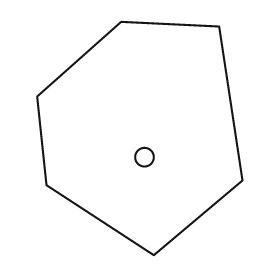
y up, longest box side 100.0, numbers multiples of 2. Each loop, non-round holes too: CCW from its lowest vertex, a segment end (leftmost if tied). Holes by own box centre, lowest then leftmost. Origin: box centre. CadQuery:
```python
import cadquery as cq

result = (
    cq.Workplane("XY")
    .moveTo(6.0, -50.0)
    .lineTo(44.0, -18.0)
    .lineTo(34.0, 48.0)
    .lineTo(-8.0, 50.0)
    .lineTo(-44.0, 18.0)
    .lineTo(-40.0, -20.0)
    .close()
    .moveTo(2.0, -8.0)
    .circle(4.0)
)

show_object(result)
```